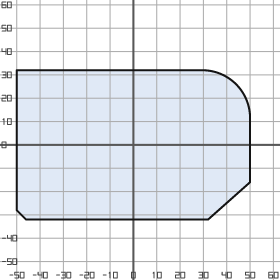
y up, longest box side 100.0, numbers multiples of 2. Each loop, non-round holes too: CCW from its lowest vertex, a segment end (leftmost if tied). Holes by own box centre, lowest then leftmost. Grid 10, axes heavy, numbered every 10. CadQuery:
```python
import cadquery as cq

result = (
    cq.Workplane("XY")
    .moveTo(-46.0, -32.0)
    .lineTo(32.0, -32.0)
    .lineTo(50.0, -16.0)
    .lineTo(50.0, 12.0)
    .threePointArc((44.0, 26.0), (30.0, 32.0))
    .lineTo(-50.0, 32.0)
    .lineTo(-50.0, -28.0)
    .close()
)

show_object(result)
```